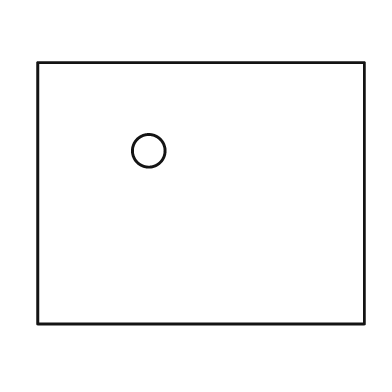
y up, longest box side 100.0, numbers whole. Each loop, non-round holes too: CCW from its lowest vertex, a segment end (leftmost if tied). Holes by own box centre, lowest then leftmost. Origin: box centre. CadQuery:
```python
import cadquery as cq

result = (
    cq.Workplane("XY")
    .moveTo(-50.0, -40.0)
    .lineTo(50.0, -40.0)
    .lineTo(50.0, 40.0)
    .lineTo(-50.0, 40.0)
    .close()
    .moveTo(-16.0, 13.0)
    .circle(5.0)
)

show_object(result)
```